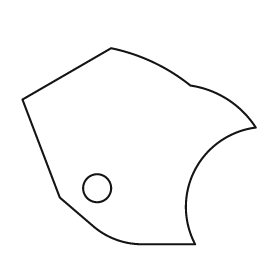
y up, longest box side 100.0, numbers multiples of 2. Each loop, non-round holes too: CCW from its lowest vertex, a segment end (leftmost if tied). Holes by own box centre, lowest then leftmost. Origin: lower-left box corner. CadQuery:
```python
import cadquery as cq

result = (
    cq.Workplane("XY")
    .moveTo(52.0, 0.0)
    .lineTo(74.0, 0.0)
    .threePointArc((74.0, 32.0), (100.0, 50.0))
    .threePointArc((88.0, 62.0), (72.0, 68.0))
    .threePointArc((56.0, 78.0), (38.0, 84.0))
    .lineTo(0.0, 62.0)
    .lineTo(16.0, 20.0)
    .lineTo(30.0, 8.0)
    .threePointArc((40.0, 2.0), (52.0, 0.0))
    .close()
    .moveTo(32.0, 24.0)
    .circle(6.0)
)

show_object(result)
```